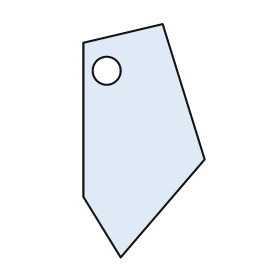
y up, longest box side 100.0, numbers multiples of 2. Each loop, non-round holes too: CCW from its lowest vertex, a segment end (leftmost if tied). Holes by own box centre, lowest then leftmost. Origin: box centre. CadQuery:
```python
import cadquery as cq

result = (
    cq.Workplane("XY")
    .moveTo(-10.0, -50.0)
    .lineTo(26.0, -8.0)
    .lineTo(8.0, 50.0)
    .lineTo(-26.0, 42.0)
    .lineTo(-26.0, -24.0)
    .close()
    .moveTo(-16.0, 30.0)
    .circle(6.0)
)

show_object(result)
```